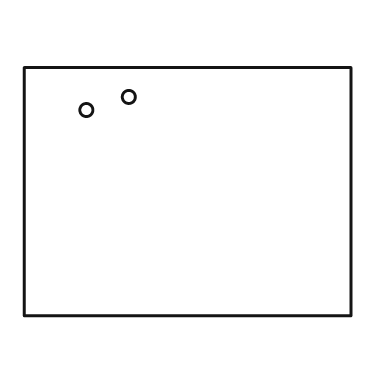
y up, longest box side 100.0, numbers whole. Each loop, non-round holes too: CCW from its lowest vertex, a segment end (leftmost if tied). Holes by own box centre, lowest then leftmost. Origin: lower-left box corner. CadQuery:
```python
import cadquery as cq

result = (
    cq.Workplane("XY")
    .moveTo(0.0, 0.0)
    .lineTo(100.0, 0.0)
    .lineTo(100.0, 76.0)
    .lineTo(0.0, 76.0)
    .close()
    .moveTo(19.0, 63.0)
    .circle(2.0)
    .moveTo(32.0, 67.0)
    .circle(2.0)
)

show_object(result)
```